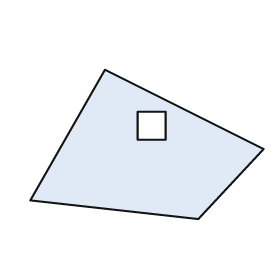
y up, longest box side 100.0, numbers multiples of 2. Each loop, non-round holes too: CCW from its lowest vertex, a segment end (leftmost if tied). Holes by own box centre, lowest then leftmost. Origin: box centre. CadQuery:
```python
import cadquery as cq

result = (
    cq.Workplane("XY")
    .moveTo(22.0, -32.0)
    .lineTo(50.0, -2.0)
    .lineTo(-18.0, 32.0)
    .lineTo(-50.0, -24.0)
    .close()
    .moveTo(-4.0, 2.0)
    .lineTo(8.0, 2.0)
    .lineTo(8.0, 14.0)
    .lineTo(-4.0, 14.0)
    .close()
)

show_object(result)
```